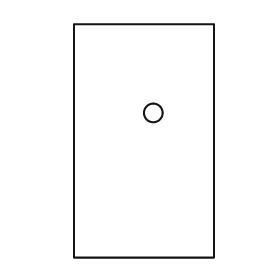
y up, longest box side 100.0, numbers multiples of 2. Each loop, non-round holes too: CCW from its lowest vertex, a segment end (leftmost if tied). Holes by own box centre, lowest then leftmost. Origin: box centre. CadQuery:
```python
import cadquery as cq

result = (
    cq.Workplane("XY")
    .moveTo(-30.0, -50.0)
    .lineTo(30.0, -50.0)
    .lineTo(30.0, 50.0)
    .lineTo(-30.0, 50.0)
    .close()
    .moveTo(4.0, 12.0)
    .circle(4.0)
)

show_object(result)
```